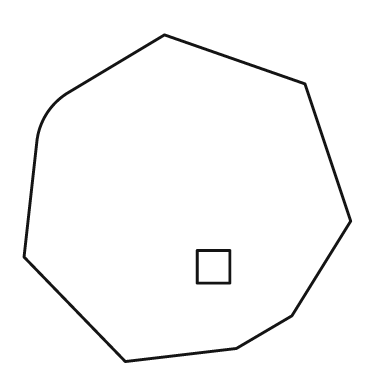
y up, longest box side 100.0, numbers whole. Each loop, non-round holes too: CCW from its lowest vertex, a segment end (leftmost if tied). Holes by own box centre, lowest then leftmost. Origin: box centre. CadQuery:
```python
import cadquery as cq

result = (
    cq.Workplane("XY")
    .moveTo(-19.0, -50.0)
    .lineTo(15.0, -46.0)
    .lineTo(32.0, -36.0)
    .lineTo(50.0, -7.0)
    .lineTo(36.0, 35.0)
    .lineTo(-7.0, 50.0)
    .lineTo(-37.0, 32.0)
    .threePointArc((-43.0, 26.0), (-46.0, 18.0))
    .lineTo(-50.0, -18.0)
    .close()
    .moveTo(3.0, -26.0)
    .lineTo(13.0, -26.0)
    .lineTo(13.0, -16.0)
    .lineTo(3.0, -16.0)
    .close()
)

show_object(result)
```